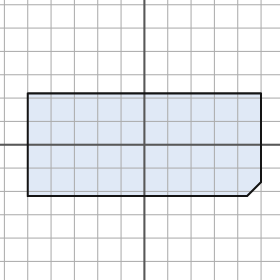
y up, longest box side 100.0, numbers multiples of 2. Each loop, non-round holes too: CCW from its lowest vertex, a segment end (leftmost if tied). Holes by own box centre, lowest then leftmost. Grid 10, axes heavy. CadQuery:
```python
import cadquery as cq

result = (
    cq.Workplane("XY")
    .moveTo(-50.0, -22.0)
    .lineTo(44.0, -22.0)
    .lineTo(50.0, -16.0)
    .lineTo(50.0, 22.0)
    .lineTo(-50.0, 22.0)
    .close()
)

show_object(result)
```